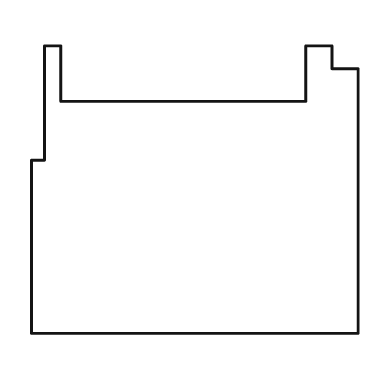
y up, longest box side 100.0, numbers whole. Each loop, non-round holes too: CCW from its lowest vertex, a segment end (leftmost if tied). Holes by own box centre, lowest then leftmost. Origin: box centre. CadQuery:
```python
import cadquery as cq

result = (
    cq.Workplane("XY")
    .moveTo(-50.0, -44.0)
    .lineTo(50.0, -44.0)
    .lineTo(50.0, 37.0)
    .lineTo(42.0, 37.0)
    .lineTo(42.0, 44.0)
    .lineTo(34.0, 44.0)
    .lineTo(34.0, 27.0)
    .lineTo(-41.0, 27.0)
    .lineTo(-41.0, 44.0)
    .lineTo(-46.0, 44.0)
    .lineTo(-46.0, 9.0)
    .lineTo(-50.0, 9.0)
    .close()
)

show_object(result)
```